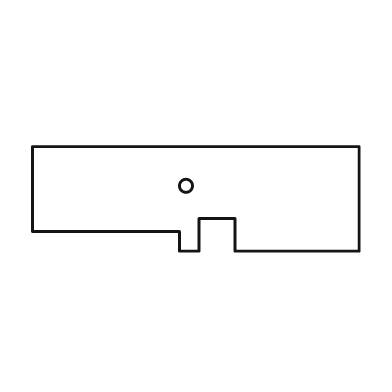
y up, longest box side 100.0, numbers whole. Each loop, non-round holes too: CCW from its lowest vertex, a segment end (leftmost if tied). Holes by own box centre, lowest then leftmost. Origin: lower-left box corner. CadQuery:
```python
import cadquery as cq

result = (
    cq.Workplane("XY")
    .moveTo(45.0, 0.0)
    .lineTo(51.0, 0.0)
    .lineTo(51.0, 10.0)
    .lineTo(62.0, 10.0)
    .lineTo(62.0, 0.0)
    .lineTo(100.0, 0.0)
    .lineTo(100.0, 32.0)
    .lineTo(0.0, 32.0)
    .lineTo(0.0, 6.0)
    .lineTo(45.0, 6.0)
    .close()
    .moveTo(47.0, 20.0)
    .circle(2.0)
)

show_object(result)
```